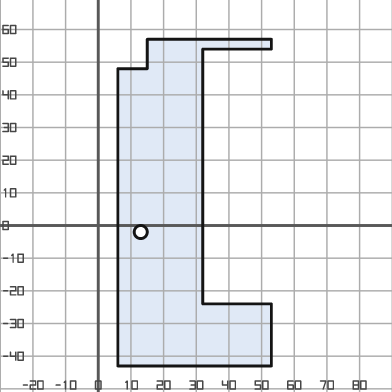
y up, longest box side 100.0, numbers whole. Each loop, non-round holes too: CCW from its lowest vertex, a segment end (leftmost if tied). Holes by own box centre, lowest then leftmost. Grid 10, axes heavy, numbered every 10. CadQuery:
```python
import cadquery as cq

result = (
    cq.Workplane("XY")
    .moveTo(6.0, -43.0)
    .lineTo(53.0, -43.0)
    .lineTo(53.0, -24.0)
    .lineTo(32.0, -24.0)
    .lineTo(32.0, 54.0)
    .lineTo(53.0, 54.0)
    .lineTo(53.0, 57.0)
    .lineTo(15.0, 57.0)
    .lineTo(15.0, 48.0)
    .lineTo(6.0, 48.0)
    .close()
    .moveTo(13.0, -2.0)
    .circle(2.0)
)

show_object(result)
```